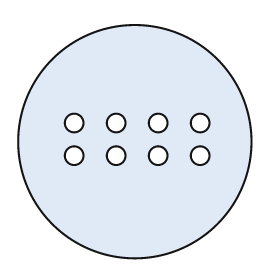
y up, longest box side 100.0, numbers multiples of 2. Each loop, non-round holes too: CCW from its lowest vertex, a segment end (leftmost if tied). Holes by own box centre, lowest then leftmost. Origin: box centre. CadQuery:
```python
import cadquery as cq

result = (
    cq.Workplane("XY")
    .moveTo(0.0, 0.0)
    .circle(50.0)
    .moveTo(-26.0, -6.0)
    .circle(4.0)
    .moveTo(-8.0, -6.0)
    .circle(4.0)
    .moveTo(10.0, -6.0)
    .circle(4.0)
    .moveTo(28.0, -6.0)
    .circle(4.0)
    .moveTo(-26.0, 8.0)
    .circle(4.0)
    .moveTo(-8.0, 8.0)
    .circle(4.0)
    .moveTo(10.0, 8.0)
    .circle(4.0)
    .moveTo(28.0, 8.0)
    .circle(4.0)
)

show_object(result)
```